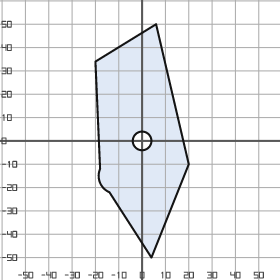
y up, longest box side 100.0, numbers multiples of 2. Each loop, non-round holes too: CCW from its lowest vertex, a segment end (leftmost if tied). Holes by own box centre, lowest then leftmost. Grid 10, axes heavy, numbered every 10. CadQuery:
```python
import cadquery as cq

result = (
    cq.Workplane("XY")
    .moveTo(4.0, -50.0)
    .lineTo(20.0, -10.0)
    .lineTo(6.0, 50.0)
    .lineTo(-20.0, 34.0)
    .lineTo(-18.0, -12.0)
    .threePointArc((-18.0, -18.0), (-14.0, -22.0))
    .close()
    .moveTo(0.0, 0.0)
    .circle(4.0)
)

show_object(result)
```